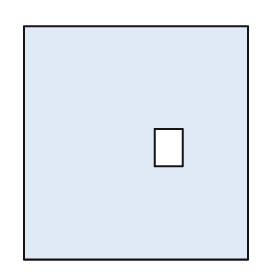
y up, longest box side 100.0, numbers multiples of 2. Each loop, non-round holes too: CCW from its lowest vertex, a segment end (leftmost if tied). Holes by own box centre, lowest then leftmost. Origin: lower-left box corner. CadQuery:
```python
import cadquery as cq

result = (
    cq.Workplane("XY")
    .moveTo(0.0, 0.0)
    .lineTo(96.0, 0.0)
    .lineTo(96.0, 100.0)
    .lineTo(0.0, 100.0)
    .close()
    .moveTo(56.0, 40.0)
    .lineTo(68.0, 40.0)
    .lineTo(68.0, 56.0)
    .lineTo(56.0, 56.0)
    .close()
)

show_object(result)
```